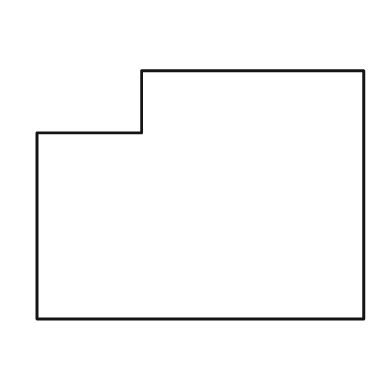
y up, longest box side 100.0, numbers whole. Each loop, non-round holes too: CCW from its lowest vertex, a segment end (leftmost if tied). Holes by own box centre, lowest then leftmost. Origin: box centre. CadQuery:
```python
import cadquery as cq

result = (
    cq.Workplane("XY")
    .moveTo(-50.0, -38.0)
    .lineTo(50.0, -38.0)
    .lineTo(50.0, 38.0)
    .lineTo(-18.0, 38.0)
    .lineTo(-18.0, 19.0)
    .lineTo(-50.0, 19.0)
    .close()
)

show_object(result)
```